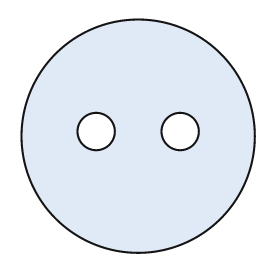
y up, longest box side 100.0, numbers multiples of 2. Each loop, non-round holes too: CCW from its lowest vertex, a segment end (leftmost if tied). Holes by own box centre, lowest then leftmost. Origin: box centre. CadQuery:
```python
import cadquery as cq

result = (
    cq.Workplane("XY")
    .moveTo(0.0, 0.0)
    .circle(50.0)
    .moveTo(-18.0, 2.0)
    .circle(8.0)
    .moveTo(18.0, 2.0)
    .circle(8.0)
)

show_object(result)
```